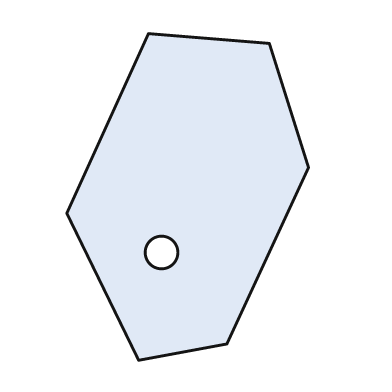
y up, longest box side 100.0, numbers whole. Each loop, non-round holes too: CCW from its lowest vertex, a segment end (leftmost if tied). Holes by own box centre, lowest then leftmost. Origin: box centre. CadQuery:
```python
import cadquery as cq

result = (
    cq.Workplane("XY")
    .moveTo(-15.0, -50.0)
    .lineTo(12.0, -45.0)
    .lineTo(37.0, 9.0)
    .lineTo(25.0, 47.0)
    .lineTo(-12.0, 50.0)
    .lineTo(-37.0, -5.0)
    .close()
    .moveTo(-8.0, -17.0)
    .circle(5.0)
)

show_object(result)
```